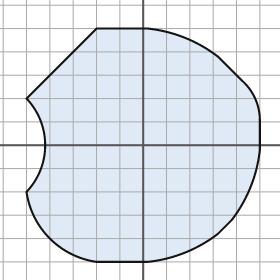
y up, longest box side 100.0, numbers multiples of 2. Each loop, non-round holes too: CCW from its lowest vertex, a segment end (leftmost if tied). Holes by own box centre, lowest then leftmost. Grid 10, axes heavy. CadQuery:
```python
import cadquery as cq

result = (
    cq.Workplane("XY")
    .moveTo(-20.0, -50.0)
    .lineTo(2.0, -50.0)
    .threePointArc((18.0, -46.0), (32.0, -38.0))
    .lineTo(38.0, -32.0)
    .threePointArc((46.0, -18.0), (50.0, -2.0))
    .lineTo(50.0, 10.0)
    .threePointArc((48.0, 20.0), (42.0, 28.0))
    .lineTo(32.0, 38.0)
    .threePointArc((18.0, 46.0), (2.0, 50.0))
    .lineTo(-20.0, 50.0)
    .lineTo(-50.0, 20.0)
    .threePointArc((-42.0, 0.0), (-50.0, -20.0))
    .threePointArc((-40.0, -40.0), (-20.0, -50.0))
    .close()
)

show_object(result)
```